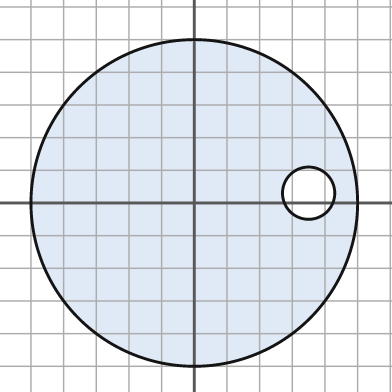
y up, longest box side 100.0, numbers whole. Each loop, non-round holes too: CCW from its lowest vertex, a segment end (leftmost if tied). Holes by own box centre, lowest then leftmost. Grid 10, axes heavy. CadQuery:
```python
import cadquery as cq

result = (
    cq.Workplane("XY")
    .moveTo(0.0, 0.0)
    .circle(50.0)
    .moveTo(35.0, 3.0)
    .circle(8.0)
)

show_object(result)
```